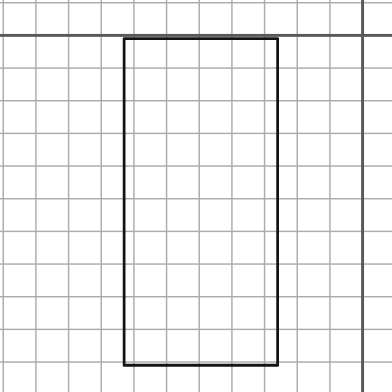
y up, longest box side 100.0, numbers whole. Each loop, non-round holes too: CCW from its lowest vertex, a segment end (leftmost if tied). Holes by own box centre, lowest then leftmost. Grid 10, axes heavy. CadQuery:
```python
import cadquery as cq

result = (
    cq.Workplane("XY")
    .moveTo(-73.0, -101.0)
    .lineTo(-26.0, -101.0)
    .lineTo(-26.0, -1.0)
    .lineTo(-73.0, -1.0)
    .close()
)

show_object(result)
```